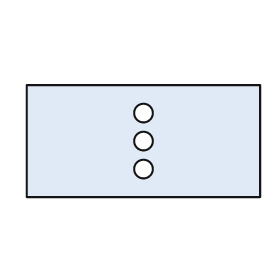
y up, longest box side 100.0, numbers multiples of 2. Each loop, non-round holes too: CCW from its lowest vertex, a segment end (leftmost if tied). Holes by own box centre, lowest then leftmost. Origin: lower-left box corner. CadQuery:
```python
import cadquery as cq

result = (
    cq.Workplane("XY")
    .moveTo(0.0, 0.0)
    .lineTo(100.0, 0.0)
    .lineTo(100.0, 48.0)
    .lineTo(0.0, 48.0)
    .close()
    .moveTo(50.0, 12.0)
    .circle(4.0)
    .moveTo(50.0, 24.0)
    .circle(4.0)
    .moveTo(50.0, 36.0)
    .circle(4.0)
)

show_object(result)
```